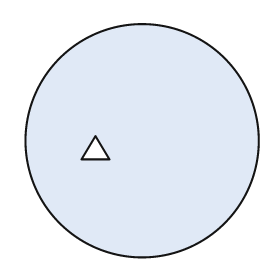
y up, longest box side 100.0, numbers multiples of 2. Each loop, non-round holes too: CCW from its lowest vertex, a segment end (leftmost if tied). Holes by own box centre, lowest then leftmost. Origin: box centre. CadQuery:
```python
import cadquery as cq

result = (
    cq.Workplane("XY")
    .moveTo(0.0, 0.0)
    .circle(50.0)
    .moveTo(-26.0, -8.0)
    .lineTo(-14.0, -8.0)
    .lineTo(-20.0, 2.0)
    .close()
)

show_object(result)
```